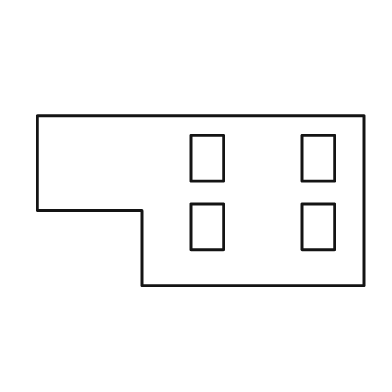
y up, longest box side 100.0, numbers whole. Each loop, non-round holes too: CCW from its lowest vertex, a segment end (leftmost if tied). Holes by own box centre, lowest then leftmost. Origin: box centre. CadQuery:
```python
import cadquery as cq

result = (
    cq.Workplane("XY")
    .moveTo(-18.0, -26.0)
    .lineTo(50.0, -26.0)
    .lineTo(50.0, 26.0)
    .lineTo(-50.0, 26.0)
    .lineTo(-50.0, -3.0)
    .lineTo(-18.0, -3.0)
    .close()
    .moveTo(-3.0, -15.0)
    .lineTo(7.0, -15.0)
    .lineTo(7.0, -1.0)
    .lineTo(-3.0, -1.0)
    .close()
    .moveTo(31.0, -15.0)
    .lineTo(41.0, -15.0)
    .lineTo(41.0, -1.0)
    .lineTo(31.0, -1.0)
    .close()
    .moveTo(-3.0, 6.0)
    .lineTo(7.0, 6.0)
    .lineTo(7.0, 20.0)
    .lineTo(-3.0, 20.0)
    .close()
    .moveTo(31.0, 6.0)
    .lineTo(41.0, 6.0)
    .lineTo(41.0, 20.0)
    .lineTo(31.0, 20.0)
    .close()
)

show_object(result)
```